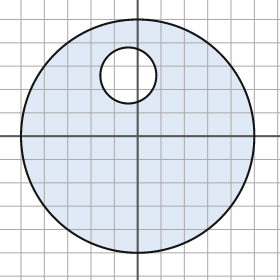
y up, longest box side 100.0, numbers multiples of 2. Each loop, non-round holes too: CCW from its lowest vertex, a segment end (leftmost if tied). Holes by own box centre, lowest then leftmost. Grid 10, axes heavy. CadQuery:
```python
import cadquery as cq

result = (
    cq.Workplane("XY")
    .moveTo(0.0, 0.0)
    .circle(50.0)
    .moveTo(-4.0, 26.0)
    .circle(12.0)
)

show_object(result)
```